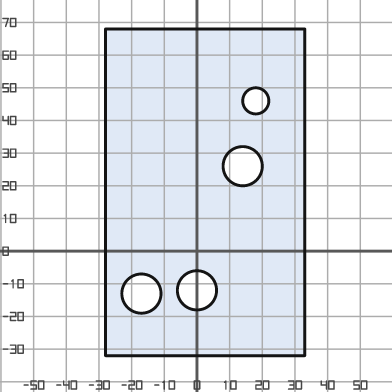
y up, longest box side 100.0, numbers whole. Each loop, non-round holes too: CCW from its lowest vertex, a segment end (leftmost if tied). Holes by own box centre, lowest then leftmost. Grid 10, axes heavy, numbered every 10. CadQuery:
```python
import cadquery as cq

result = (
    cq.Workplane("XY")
    .moveTo(-28.0, -32.0)
    .lineTo(33.0, -32.0)
    .lineTo(33.0, 68.0)
    .lineTo(-28.0, 68.0)
    .close()
    .moveTo(-17.0, -13.0)
    .circle(6.0)
    .moveTo(0.0, -12.0)
    .circle(6.0)
    .moveTo(14.0, 26.0)
    .circle(6.0)
    .moveTo(18.0, 46.0)
    .circle(4.0)
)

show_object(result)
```